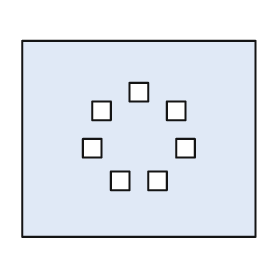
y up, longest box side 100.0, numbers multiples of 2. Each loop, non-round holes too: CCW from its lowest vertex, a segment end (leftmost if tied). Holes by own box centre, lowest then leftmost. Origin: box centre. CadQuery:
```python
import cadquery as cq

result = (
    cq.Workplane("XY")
    .moveTo(-50.0, -42.0)
    .lineTo(50.0, -42.0)
    .lineTo(50.0, 42.0)
    .lineTo(-50.0, 42.0)
    .close()
    .moveTo(-12.0, -22.0)
    .lineTo(-4.0, -22.0)
    .lineTo(-4.0, -14.0)
    .lineTo(-12.0, -14.0)
    .close()
    .moveTo(4.0, -22.0)
    .lineTo(12.0, -22.0)
    .lineTo(12.0, -14.0)
    .lineTo(4.0, -14.0)
    .close()
    .moveTo(-24.0, -8.0)
    .lineTo(-16.0, -8.0)
    .lineTo(-16.0, 0.0)
    .lineTo(-24.0, 0.0)
    .close()
    .moveTo(16.0, -8.0)
    .lineTo(24.0, -8.0)
    .lineTo(24.0, 0.0)
    .lineTo(16.0, 0.0)
    .close()
    .moveTo(-20.0, 8.0)
    .lineTo(-12.0, 8.0)
    .lineTo(-12.0, 16.0)
    .lineTo(-20.0, 16.0)
    .close()
    .moveTo(12.0, 8.0)
    .lineTo(20.0, 8.0)
    .lineTo(20.0, 16.0)
    .lineTo(12.0, 16.0)
    .close()
    .moveTo(-4.0, 16.0)
    .lineTo(4.0, 16.0)
    .lineTo(4.0, 24.0)
    .lineTo(-4.0, 24.0)
    .close()
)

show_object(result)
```